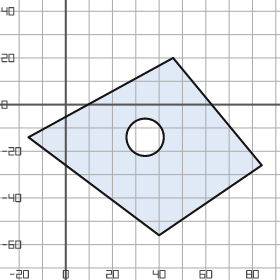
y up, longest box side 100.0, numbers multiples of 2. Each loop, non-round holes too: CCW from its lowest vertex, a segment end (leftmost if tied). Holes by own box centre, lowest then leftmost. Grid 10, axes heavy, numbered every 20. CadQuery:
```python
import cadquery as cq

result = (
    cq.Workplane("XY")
    .moveTo(40.0, -56.0)
    .lineTo(84.0, -26.0)
    .lineTo(46.0, 20.0)
    .lineTo(-16.0, -14.0)
    .close()
    .moveTo(34.0, -14.0)
    .circle(8.0)
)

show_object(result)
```